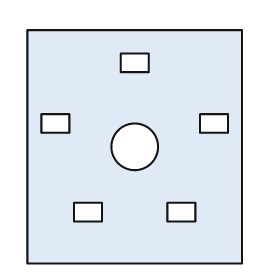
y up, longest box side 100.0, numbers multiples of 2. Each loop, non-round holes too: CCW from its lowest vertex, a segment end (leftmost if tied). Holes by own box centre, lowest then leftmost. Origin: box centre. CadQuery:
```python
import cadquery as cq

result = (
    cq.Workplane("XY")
    .moveTo(-46.0, -50.0)
    .lineTo(46.0, -50.0)
    .lineTo(46.0, 50.0)
    .lineTo(-46.0, 50.0)
    .close()
    .moveTo(-26.0, -32.0)
    .lineTo(-14.0, -32.0)
    .lineTo(-14.0, -24.0)
    .lineTo(-26.0, -24.0)
    .close()
    .moveTo(14.0, -32.0)
    .lineTo(26.0, -32.0)
    .lineTo(26.0, -24.0)
    .lineTo(14.0, -24.0)
    .close()
    .moveTo(0.0, 0.0)
    .circle(10.0)
    .moveTo(-40.0, 6.0)
    .lineTo(-28.0, 6.0)
    .lineTo(-28.0, 14.0)
    .lineTo(-40.0, 14.0)
    .close()
    .moveTo(28.0, 6.0)
    .lineTo(40.0, 6.0)
    .lineTo(40.0, 14.0)
    .lineTo(28.0, 14.0)
    .close()
    .moveTo(-6.0, 32.0)
    .lineTo(6.0, 32.0)
    .lineTo(6.0, 40.0)
    .lineTo(-6.0, 40.0)
    .close()
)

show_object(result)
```